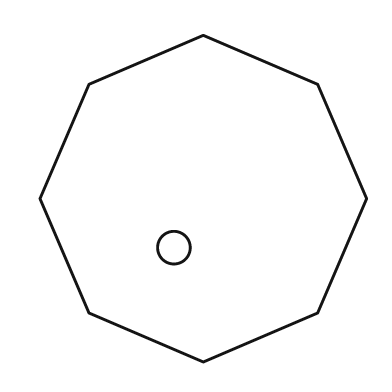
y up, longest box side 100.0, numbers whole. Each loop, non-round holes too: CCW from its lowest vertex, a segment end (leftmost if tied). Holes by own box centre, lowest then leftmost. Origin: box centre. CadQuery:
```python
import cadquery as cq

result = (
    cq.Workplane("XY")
    .moveTo(0.0, -50.0)
    .lineTo(35.0, -35.0)
    .lineTo(50.0, 0.0)
    .lineTo(35.0, 35.0)
    .lineTo(0.0, 50.0)
    .lineTo(-35.0, 35.0)
    .lineTo(-50.0, 0.0)
    .lineTo(-35.0, -35.0)
    .close()
    .moveTo(-9.0, -15.0)
    .circle(5.0)
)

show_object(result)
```